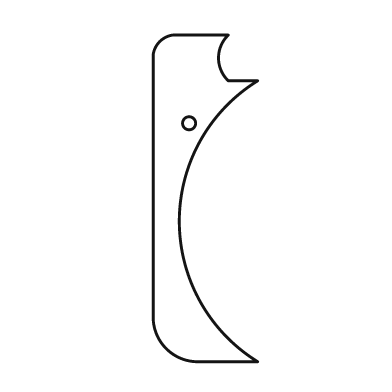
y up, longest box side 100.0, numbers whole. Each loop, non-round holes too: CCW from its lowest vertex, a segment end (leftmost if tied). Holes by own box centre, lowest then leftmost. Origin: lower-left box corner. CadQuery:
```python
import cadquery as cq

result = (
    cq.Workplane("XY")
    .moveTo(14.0, 0.0)
    .lineTo(32.0, 0.0)
    .threePointArc((8.0, 43.0), (32.0, 86.0))
    .lineTo(23.0, 86.0)
    .threePointArc((20.0, 93.0), (23.0, 100.0))
    .lineTo(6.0, 100.0)
    .threePointArc((2.0, 98.0), (0.0, 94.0))
    .lineTo(0.0, 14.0)
    .threePointArc((4.0, 4.0), (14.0, 0.0))
    .close()
    .moveTo(11.0, 73.0)
    .circle(2.0)
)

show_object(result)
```